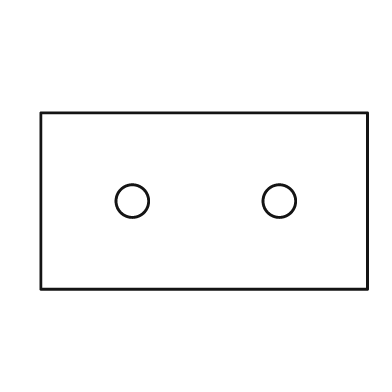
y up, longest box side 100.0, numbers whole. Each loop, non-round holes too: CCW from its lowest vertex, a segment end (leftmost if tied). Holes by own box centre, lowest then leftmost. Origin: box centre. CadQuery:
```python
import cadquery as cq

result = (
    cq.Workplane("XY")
    .moveTo(-50.0, -27.0)
    .lineTo(50.0, -27.0)
    .lineTo(50.0, 27.0)
    .lineTo(-50.0, 27.0)
    .close()
    .moveTo(-22.0, 0.0)
    .circle(5.0)
    .moveTo(23.0, 0.0)
    .circle(5.0)
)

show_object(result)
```